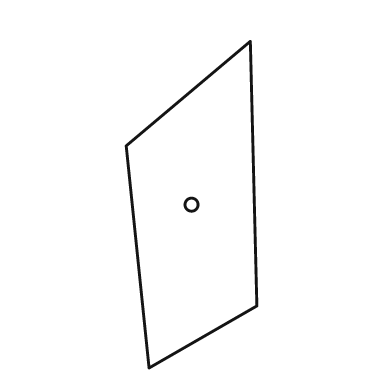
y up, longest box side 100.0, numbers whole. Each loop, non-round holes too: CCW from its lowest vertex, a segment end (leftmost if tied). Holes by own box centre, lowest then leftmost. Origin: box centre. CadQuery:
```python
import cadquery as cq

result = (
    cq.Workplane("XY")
    .moveTo(-13.0, -50.0)
    .lineTo(20.0, -31.0)
    .lineTo(18.0, 50.0)
    .lineTo(-20.0, 18.0)
    .close()
    .moveTo(0.0, 0.0)
    .circle(2.0)
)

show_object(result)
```